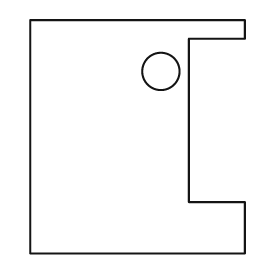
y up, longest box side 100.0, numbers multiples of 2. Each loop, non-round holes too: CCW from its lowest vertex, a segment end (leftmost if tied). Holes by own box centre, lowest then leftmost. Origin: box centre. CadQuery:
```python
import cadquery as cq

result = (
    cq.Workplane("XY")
    .moveTo(-46.0, -50.0)
    .lineTo(46.0, -50.0)
    .lineTo(46.0, -28.0)
    .lineTo(22.0, -28.0)
    .lineTo(22.0, 42.0)
    .lineTo(46.0, 42.0)
    .lineTo(46.0, 50.0)
    .lineTo(-46.0, 50.0)
    .close()
    .moveTo(10.0, 28.0)
    .circle(8.0)
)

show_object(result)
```